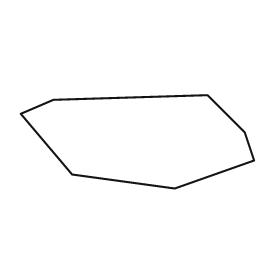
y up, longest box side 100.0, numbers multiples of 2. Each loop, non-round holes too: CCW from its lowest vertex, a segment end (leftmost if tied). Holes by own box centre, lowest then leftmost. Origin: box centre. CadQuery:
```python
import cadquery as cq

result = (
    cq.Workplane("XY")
    .moveTo(16.0, -20.0)
    .lineTo(50.0, -8.0)
    .lineTo(46.0, 4.0)
    .lineTo(30.0, 20.0)
    .lineTo(-36.0, 18.0)
    .lineTo(-50.0, 12.0)
    .lineTo(-28.0, -14.0)
    .close()
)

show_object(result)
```